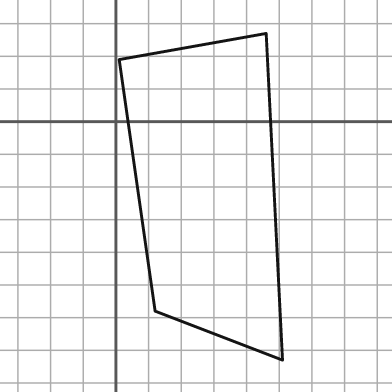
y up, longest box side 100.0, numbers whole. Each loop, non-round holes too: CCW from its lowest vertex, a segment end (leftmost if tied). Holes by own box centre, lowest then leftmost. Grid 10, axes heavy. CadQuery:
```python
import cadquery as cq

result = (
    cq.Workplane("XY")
    .moveTo(51.0, -73.0)
    .lineTo(46.0, 27.0)
    .lineTo(1.0, 19.0)
    .lineTo(12.0, -58.0)
    .close()
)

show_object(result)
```